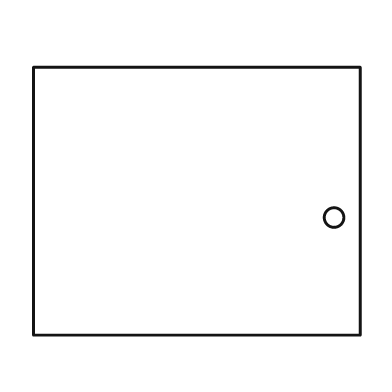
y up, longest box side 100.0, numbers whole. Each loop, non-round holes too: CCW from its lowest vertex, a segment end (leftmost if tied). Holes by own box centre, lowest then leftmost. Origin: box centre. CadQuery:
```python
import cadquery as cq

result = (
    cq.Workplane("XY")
    .moveTo(-50.0, -41.0)
    .lineTo(50.0, -41.0)
    .lineTo(50.0, 41.0)
    .lineTo(-50.0, 41.0)
    .close()
    .moveTo(42.0, -5.0)
    .circle(3.0)
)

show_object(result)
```